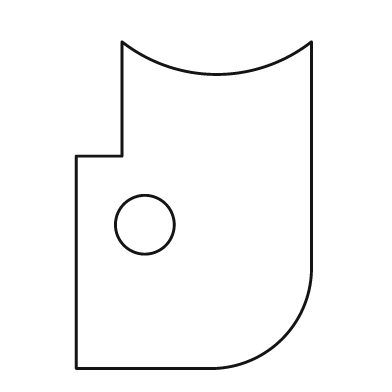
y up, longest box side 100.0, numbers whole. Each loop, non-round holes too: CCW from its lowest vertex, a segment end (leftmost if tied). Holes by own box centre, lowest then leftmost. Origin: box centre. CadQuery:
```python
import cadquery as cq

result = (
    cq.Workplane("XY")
    .moveTo(-36.0, -50.0)
    .lineTo(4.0, -50.0)
    .threePointArc((27.0, -41.0), (36.0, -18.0))
    .lineTo(36.0, 50.0)
    .threePointArc((7.0, 40.0), (-22.0, 50.0))
    .lineTo(-22.0, 15.0)
    .lineTo(-36.0, 15.0)
    .close()
    .moveTo(-15.0, -6.0)
    .circle(9.0)
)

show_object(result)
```